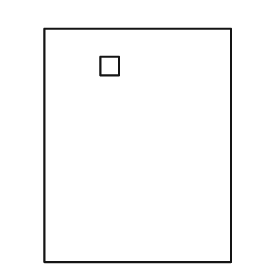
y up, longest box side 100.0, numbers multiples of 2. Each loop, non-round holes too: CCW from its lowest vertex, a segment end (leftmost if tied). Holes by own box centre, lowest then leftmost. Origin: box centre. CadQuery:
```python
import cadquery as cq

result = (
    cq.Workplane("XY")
    .moveTo(-40.0, -50.0)
    .lineTo(40.0, -50.0)
    .lineTo(40.0, 50.0)
    .lineTo(-40.0, 50.0)
    .close()
    .moveTo(-16.0, 30.0)
    .lineTo(-8.0, 30.0)
    .lineTo(-8.0, 38.0)
    .lineTo(-16.0, 38.0)
    .close()
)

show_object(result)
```